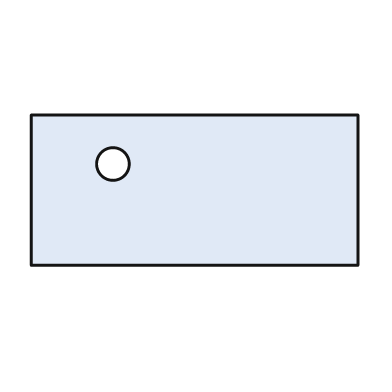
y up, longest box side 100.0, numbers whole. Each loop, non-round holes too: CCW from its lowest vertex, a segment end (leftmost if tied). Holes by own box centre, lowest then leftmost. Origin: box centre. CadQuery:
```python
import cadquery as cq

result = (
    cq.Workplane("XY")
    .moveTo(-50.0, -23.0)
    .lineTo(50.0, -23.0)
    .lineTo(50.0, 23.0)
    .lineTo(-50.0, 23.0)
    .close()
    .moveTo(-25.0, 8.0)
    .circle(5.0)
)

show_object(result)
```